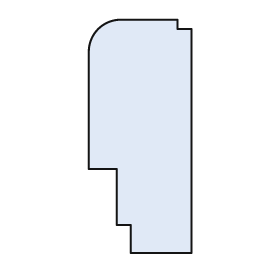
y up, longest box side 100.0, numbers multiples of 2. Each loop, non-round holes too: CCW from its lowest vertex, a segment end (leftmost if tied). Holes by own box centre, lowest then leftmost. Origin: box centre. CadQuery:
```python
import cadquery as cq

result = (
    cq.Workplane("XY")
    .moveTo(-4.0, -50.0)
    .lineTo(22.0, -50.0)
    .lineTo(22.0, 46.0)
    .lineTo(16.0, 46.0)
    .lineTo(16.0, 50.0)
    .lineTo(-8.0, 50.0)
    .threePointArc((-18.0, 46.0), (-22.0, 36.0))
    .lineTo(-22.0, -14.0)
    .lineTo(-10.0, -14.0)
    .lineTo(-10.0, -38.0)
    .lineTo(-4.0, -38.0)
    .close()
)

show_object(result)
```